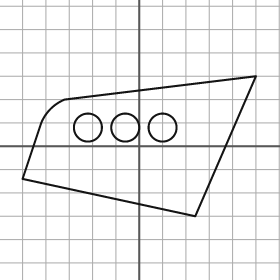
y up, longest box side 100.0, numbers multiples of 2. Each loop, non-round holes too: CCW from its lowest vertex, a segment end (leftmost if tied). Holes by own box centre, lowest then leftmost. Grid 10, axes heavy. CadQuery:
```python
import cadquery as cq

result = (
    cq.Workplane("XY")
    .moveTo(24.0, -30.0)
    .lineTo(50.0, 30.0)
    .lineTo(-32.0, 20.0)
    .threePointArc((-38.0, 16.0), (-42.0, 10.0))
    .lineTo(-50.0, -14.0)
    .close()
    .moveTo(-22.0, 8.0)
    .circle(6.0)
    .moveTo(-6.0, 8.0)
    .circle(6.0)
    .moveTo(10.0, 8.0)
    .circle(6.0)
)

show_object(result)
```